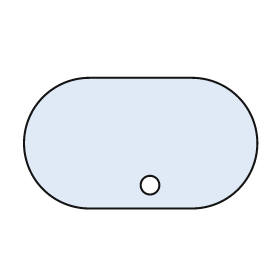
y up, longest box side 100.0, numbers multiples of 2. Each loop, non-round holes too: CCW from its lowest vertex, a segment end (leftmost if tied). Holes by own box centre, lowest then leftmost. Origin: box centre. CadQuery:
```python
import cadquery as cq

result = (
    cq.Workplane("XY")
    .moveTo(-22.0, -28.0)
    .lineTo(22.0, -28.0)
    .threePointArc((50.0, 0.0), (22.0, 28.0))
    .lineTo(-22.0, 28.0)
    .threePointArc((-50.0, 0.0), (-22.0, -28.0))
    .close()
    .moveTo(4.0, -18.0)
    .circle(4.0)
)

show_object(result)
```